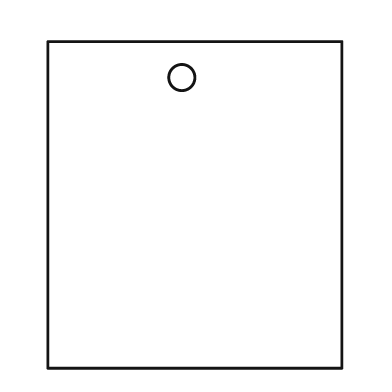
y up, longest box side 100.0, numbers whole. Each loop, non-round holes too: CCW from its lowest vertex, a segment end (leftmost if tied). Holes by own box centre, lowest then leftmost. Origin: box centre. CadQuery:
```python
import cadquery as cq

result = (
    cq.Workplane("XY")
    .moveTo(-45.0, -50.0)
    .lineTo(45.0, -50.0)
    .lineTo(45.0, 50.0)
    .lineTo(-45.0, 50.0)
    .close()
    .moveTo(-4.0, 39.0)
    .circle(4.0)
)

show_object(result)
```